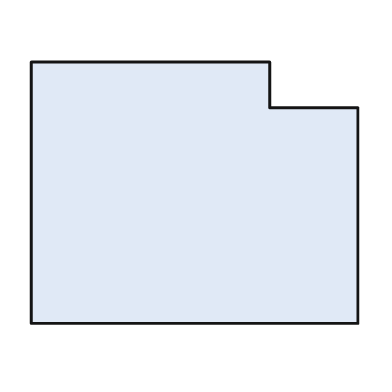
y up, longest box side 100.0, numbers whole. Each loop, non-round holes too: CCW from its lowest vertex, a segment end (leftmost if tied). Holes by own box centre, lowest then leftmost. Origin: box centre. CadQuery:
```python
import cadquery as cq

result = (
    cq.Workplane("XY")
    .moveTo(-50.0, -40.0)
    .lineTo(50.0, -40.0)
    .lineTo(50.0, 26.0)
    .lineTo(23.0, 26.0)
    .lineTo(23.0, 40.0)
    .lineTo(-50.0, 40.0)
    .close()
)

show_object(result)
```